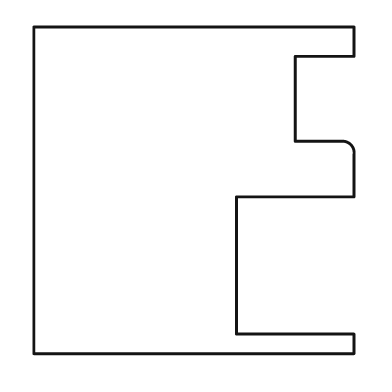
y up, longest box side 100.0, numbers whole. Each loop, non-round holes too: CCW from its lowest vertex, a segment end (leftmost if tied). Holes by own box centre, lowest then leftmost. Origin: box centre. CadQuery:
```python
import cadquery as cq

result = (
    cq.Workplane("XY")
    .moveTo(-49.0, -50.0)
    .lineTo(49.0, -50.0)
    .lineTo(49.0, -44.0)
    .lineTo(13.0, -44.0)
    .lineTo(13.0, -2.0)
    .lineTo(49.0, -2.0)
    .lineTo(49.0, 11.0)
    .threePointArc((48.0, 14.0), (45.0, 15.0))
    .lineTo(31.0, 15.0)
    .lineTo(31.0, 41.0)
    .lineTo(49.0, 41.0)
    .lineTo(49.0, 50.0)
    .lineTo(-49.0, 50.0)
    .close()
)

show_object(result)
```